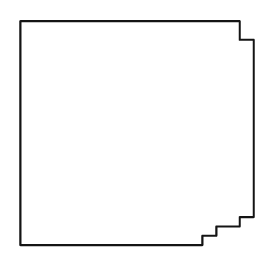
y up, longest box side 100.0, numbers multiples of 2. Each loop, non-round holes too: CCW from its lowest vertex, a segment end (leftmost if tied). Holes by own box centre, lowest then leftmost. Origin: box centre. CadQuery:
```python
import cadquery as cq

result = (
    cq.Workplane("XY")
    .moveTo(-50.0, -48.0)
    .lineTo(28.0, -48.0)
    .lineTo(28.0, -44.0)
    .lineTo(34.0, -44.0)
    .lineTo(34.0, -40.0)
    .lineTo(44.0, -40.0)
    .lineTo(44.0, -36.0)
    .lineTo(50.0, -36.0)
    .lineTo(50.0, 40.0)
    .lineTo(44.0, 40.0)
    .lineTo(44.0, 48.0)
    .lineTo(-50.0, 48.0)
    .close()
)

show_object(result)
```